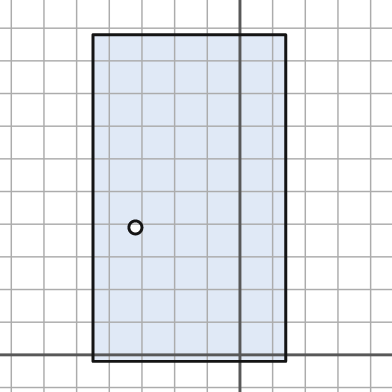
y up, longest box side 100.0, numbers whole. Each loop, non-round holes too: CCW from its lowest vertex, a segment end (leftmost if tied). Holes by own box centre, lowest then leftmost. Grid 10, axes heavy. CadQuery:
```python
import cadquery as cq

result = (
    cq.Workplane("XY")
    .moveTo(-45.0, -2.0)
    .lineTo(14.0, -2.0)
    .lineTo(14.0, 98.0)
    .lineTo(-45.0, 98.0)
    .close()
    .moveTo(-32.0, 39.0)
    .circle(2.0)
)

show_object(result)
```